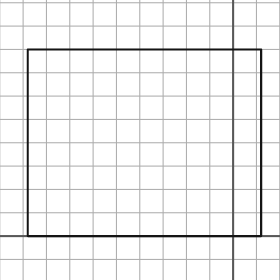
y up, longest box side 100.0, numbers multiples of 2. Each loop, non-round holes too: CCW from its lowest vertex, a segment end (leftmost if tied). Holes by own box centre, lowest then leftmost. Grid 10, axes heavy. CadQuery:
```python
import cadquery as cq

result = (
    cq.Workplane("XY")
    .moveTo(-88.0, 0.0)
    .lineTo(12.0, 0.0)
    .lineTo(12.0, 80.0)
    .lineTo(-88.0, 80.0)
    .close()
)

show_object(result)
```